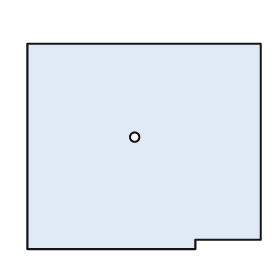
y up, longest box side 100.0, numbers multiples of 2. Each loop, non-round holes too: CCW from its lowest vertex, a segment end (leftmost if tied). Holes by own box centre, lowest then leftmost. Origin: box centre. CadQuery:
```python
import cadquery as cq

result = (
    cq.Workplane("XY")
    .moveTo(-50.0, -44.0)
    .lineTo(22.0, -44.0)
    .lineTo(22.0, -40.0)
    .lineTo(50.0, -40.0)
    .lineTo(50.0, 44.0)
    .lineTo(-50.0, 44.0)
    .close()
    .moveTo(-4.0, 4.0)
    .circle(2.0)
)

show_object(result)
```